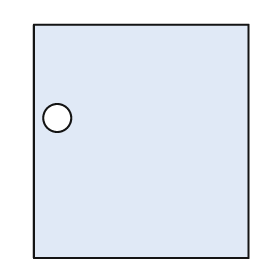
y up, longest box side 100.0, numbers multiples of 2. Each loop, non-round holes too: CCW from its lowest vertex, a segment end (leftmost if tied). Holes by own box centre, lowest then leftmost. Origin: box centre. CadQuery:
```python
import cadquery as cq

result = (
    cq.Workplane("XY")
    .moveTo(-46.0, -50.0)
    .lineTo(46.0, -50.0)
    .lineTo(46.0, 50.0)
    .lineTo(-46.0, 50.0)
    .close()
    .moveTo(-36.0, 10.0)
    .circle(6.0)
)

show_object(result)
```